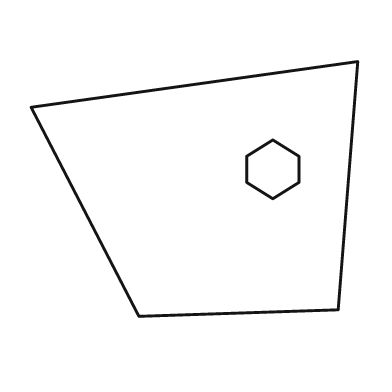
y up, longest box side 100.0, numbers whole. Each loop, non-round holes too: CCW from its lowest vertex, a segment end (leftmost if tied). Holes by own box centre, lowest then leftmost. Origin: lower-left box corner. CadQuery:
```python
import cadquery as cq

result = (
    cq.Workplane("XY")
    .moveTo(33.0, 0.0)
    .lineTo(94.0, 2.0)
    .lineTo(100.0, 78.0)
    .lineTo(0.0, 64.0)
    .close()
    .moveTo(74.0, 36.0)
    .lineTo(82.0, 41.0)
    .lineTo(82.0, 49.0)
    .lineTo(74.0, 54.0)
    .lineTo(66.0, 49.0)
    .lineTo(66.0, 41.0)
    .close()
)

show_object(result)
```